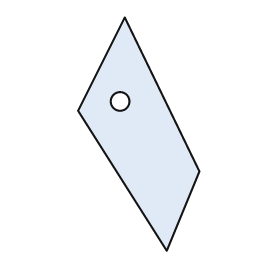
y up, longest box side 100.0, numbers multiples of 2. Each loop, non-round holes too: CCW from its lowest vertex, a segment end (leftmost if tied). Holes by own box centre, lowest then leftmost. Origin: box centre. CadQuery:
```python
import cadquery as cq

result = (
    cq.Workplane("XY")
    .moveTo(12.0, -50.0)
    .lineTo(26.0, -16.0)
    .lineTo(-6.0, 50.0)
    .lineTo(-26.0, 10.0)
    .close()
    .moveTo(-8.0, 14.0)
    .circle(4.0)
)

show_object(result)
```